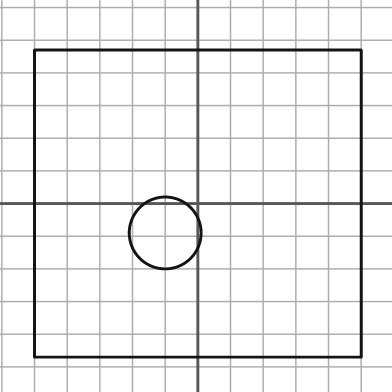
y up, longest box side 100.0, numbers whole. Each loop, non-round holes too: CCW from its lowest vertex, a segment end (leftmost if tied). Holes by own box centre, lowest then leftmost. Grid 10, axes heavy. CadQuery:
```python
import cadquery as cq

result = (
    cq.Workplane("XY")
    .moveTo(-50.0, -47.0)
    .lineTo(50.0, -47.0)
    .lineTo(50.0, 47.0)
    .lineTo(-50.0, 47.0)
    .close()
    .moveTo(-10.0, -9.0)
    .circle(11.0)
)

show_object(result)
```